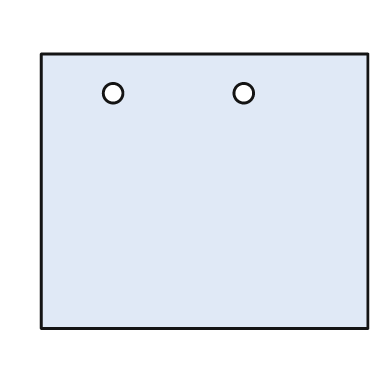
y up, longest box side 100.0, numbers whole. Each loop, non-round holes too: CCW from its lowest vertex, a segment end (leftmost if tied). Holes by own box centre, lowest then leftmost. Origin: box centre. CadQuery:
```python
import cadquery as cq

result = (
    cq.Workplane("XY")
    .moveTo(-50.0, -42.0)
    .lineTo(50.0, -42.0)
    .lineTo(50.0, 42.0)
    .lineTo(-50.0, 42.0)
    .close()
    .moveTo(-28.0, 30.0)
    .circle(3.0)
    .moveTo(12.0, 30.0)
    .circle(3.0)
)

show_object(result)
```